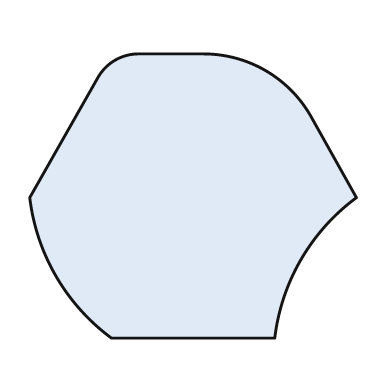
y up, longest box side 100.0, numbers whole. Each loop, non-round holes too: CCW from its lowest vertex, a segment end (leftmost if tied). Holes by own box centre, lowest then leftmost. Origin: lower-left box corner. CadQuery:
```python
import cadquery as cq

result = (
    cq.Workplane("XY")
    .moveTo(25.0, 0.0)
    .lineTo(75.0, 0.0)
    .threePointArc((83.0, 24.0), (100.0, 43.0))
    .lineTo(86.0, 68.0)
    .threePointArc((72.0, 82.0), (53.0, 87.0))
    .lineTo(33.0, 87.0)
    .threePointArc((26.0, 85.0), (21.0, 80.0))
    .lineTo(0.0, 43.0)
    .threePointArc((8.0, 19.0), (25.0, 0.0))
    .close()
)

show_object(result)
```